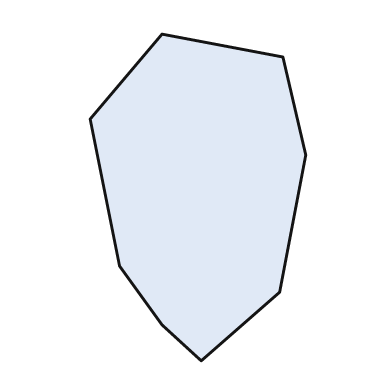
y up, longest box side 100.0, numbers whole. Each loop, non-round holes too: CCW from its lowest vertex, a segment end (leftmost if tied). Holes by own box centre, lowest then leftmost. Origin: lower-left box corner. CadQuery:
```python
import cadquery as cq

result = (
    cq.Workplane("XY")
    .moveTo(34.0, 0.0)
    .lineTo(58.0, 21.0)
    .lineTo(66.0, 63.0)
    .lineTo(59.0, 93.0)
    .lineTo(22.0, 100.0)
    .lineTo(0.0, 74.0)
    .lineTo(9.0, 29.0)
    .lineTo(22.0, 11.0)
    .close()
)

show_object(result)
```